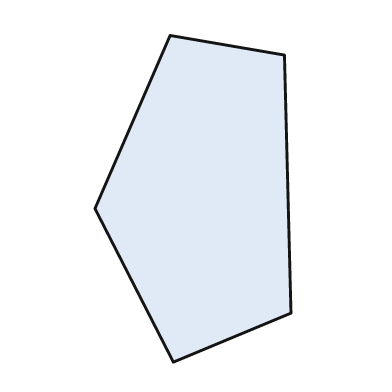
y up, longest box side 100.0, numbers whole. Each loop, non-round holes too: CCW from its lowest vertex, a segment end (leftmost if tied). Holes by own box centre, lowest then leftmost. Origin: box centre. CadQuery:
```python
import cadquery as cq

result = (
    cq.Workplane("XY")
    .moveTo(-6.0, -50.0)
    .lineTo(30.0, -35.0)
    .lineTo(28.0, 44.0)
    .lineTo(-7.0, 50.0)
    .lineTo(-30.0, -3.0)
    .close()
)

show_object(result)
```